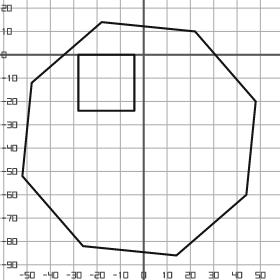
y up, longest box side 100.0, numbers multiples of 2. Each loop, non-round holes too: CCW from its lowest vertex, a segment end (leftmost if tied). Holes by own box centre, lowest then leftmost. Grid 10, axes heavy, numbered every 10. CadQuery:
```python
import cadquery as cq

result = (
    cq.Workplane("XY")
    .moveTo(14.0, -86.0)
    .lineTo(44.0, -60.0)
    .lineTo(48.0, -20.0)
    .lineTo(22.0, 10.0)
    .lineTo(-18.0, 14.0)
    .lineTo(-48.0, -12.0)
    .lineTo(-52.0, -52.0)
    .lineTo(-26.0, -82.0)
    .close()
    .moveTo(-28.0, -24.0)
    .lineTo(-4.0, -24.0)
    .lineTo(-4.0, 0.0)
    .lineTo(-28.0, 0.0)
    .close()
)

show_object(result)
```